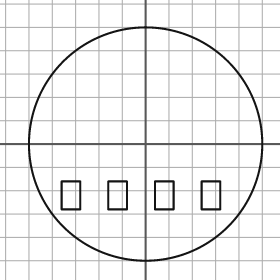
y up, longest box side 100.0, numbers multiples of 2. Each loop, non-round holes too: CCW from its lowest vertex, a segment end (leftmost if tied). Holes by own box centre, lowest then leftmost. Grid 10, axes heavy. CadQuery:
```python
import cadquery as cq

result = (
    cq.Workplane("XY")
    .moveTo(0.0, 0.0)
    .circle(50.0)
    .moveTo(-36.0, -28.0)
    .lineTo(-28.0, -28.0)
    .lineTo(-28.0, -16.0)
    .lineTo(-36.0, -16.0)
    .close()
    .moveTo(-16.0, -28.0)
    .lineTo(-8.0, -28.0)
    .lineTo(-8.0, -16.0)
    .lineTo(-16.0, -16.0)
    .close()
    .moveTo(4.0, -28.0)
    .lineTo(12.0, -28.0)
    .lineTo(12.0, -16.0)
    .lineTo(4.0, -16.0)
    .close()
    .moveTo(24.0, -28.0)
    .lineTo(32.0, -28.0)
    .lineTo(32.0, -16.0)
    .lineTo(24.0, -16.0)
    .close()
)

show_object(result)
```